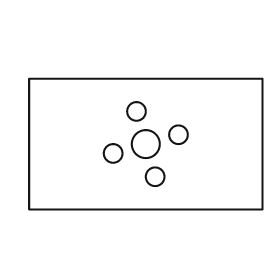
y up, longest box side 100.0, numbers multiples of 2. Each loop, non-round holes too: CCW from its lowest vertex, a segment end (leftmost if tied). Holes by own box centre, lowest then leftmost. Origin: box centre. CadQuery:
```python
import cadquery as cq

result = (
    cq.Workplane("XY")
    .moveTo(-50.0, -28.0)
    .lineTo(50.0, -28.0)
    .lineTo(50.0, 28.0)
    .lineTo(-50.0, 28.0)
    .close()
    .moveTo(4.0, -14.0)
    .circle(4.0)
    .moveTo(-14.0, -4.0)
    .circle(4.0)
    .moveTo(0.0, 0.0)
    .circle(6.0)
    .moveTo(14.0, 4.0)
    .circle(4.0)
    .moveTo(-4.0, 14.0)
    .circle(4.0)
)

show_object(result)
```